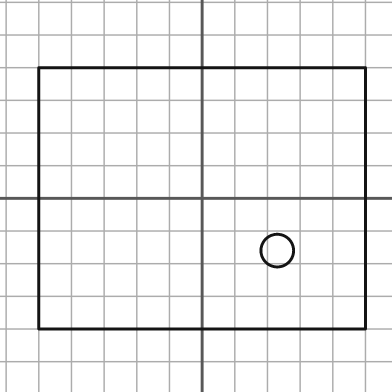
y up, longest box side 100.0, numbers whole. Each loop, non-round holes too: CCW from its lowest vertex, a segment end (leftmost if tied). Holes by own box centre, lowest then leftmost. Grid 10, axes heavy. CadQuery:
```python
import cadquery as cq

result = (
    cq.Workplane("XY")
    .moveTo(-50.0, -40.0)
    .lineTo(50.0, -40.0)
    .lineTo(50.0, 40.0)
    .lineTo(-50.0, 40.0)
    .close()
    .moveTo(23.0, -16.0)
    .circle(5.0)
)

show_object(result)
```